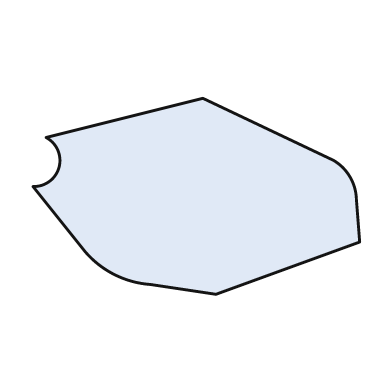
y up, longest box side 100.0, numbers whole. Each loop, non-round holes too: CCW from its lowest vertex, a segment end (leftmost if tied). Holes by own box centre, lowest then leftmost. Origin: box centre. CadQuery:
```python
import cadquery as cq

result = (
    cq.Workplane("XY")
    .moveTo(6.0, -30.0)
    .lineTo(50.0, -14.0)
    .lineTo(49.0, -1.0)
    .threePointArc((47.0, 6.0), (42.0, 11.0))
    .lineTo(2.0, 30.0)
    .lineTo(-46.0, 18.0)
    .threePointArc((-42.0, 9.0), (-50.0, 3.0))
    .lineTo(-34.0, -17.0)
    .threePointArc((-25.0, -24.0), (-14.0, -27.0))
    .close()
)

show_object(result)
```